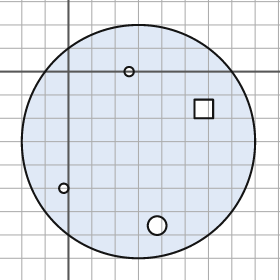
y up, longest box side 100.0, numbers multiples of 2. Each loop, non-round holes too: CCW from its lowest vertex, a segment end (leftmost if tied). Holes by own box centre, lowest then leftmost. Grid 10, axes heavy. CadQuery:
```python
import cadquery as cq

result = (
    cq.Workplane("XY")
    .moveTo(30.0, -30.0)
    .circle(50.0)
    .moveTo(38.0, -66.0)
    .circle(4.0)
    .moveTo(-2.0, -50.0)
    .circle(2.0)
    .moveTo(54.0, -20.0)
    .lineTo(62.0, -20.0)
    .lineTo(62.0, -12.0)
    .lineTo(54.0, -12.0)
    .close()
    .moveTo(26.0, 0.0)
    .circle(2.0)
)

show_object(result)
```